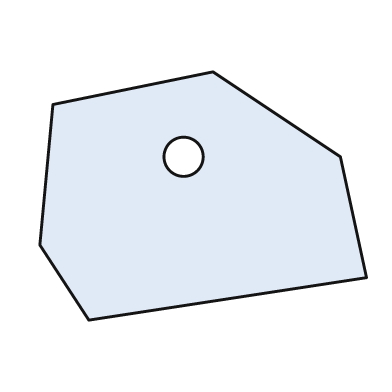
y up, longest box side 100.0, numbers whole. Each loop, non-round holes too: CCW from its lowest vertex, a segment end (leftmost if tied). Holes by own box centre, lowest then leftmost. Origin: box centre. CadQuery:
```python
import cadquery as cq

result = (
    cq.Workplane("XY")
    .moveTo(-35.0, -38.0)
    .lineTo(50.0, -25.0)
    .lineTo(42.0, 12.0)
    .lineTo(3.0, 38.0)
    .lineTo(-46.0, 28.0)
    .lineTo(-50.0, -15.0)
    .close()
    .moveTo(-6.0, 12.0)
    .circle(6.0)
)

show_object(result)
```